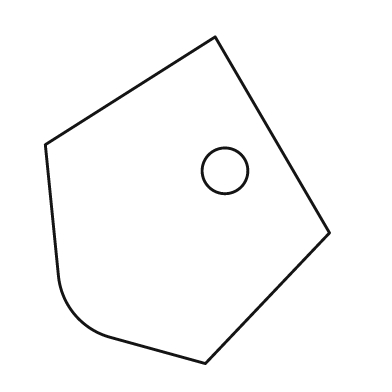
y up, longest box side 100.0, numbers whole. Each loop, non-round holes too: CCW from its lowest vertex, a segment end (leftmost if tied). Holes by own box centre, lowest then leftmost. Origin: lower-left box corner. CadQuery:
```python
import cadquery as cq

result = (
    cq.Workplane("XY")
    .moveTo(49.0, 0.0)
    .lineTo(87.0, 40.0)
    .lineTo(52.0, 100.0)
    .lineTo(0.0, 67.0)
    .lineTo(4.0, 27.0)
    .threePointArc((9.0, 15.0), (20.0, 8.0))
    .close()
    .moveTo(55.0, 59.0)
    .circle(7.0)
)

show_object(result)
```